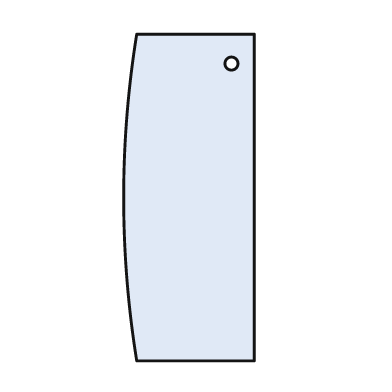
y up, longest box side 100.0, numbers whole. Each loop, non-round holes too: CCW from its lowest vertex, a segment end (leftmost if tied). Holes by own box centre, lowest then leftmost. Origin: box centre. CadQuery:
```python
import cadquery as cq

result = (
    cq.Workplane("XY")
    .moveTo(-16.0, -50.0)
    .lineTo(20.0, -50.0)
    .lineTo(20.0, 50.0)
    .lineTo(-16.0, 50.0)
    .threePointArc((-20.0, 0.0), (-16.0, -50.0))
    .close()
    .moveTo(13.0, 41.0)
    .circle(2.0)
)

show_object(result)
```